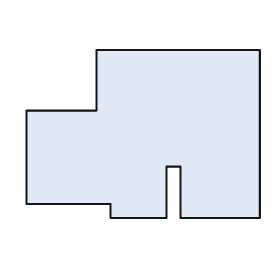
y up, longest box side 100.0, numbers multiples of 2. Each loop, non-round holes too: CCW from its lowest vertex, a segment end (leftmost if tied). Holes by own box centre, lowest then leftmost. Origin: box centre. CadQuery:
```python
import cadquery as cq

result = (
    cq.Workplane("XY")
    .moveTo(-14.0, -36.0)
    .lineTo(10.0, -36.0)
    .lineTo(10.0, -14.0)
    .lineTo(16.0, -14.0)
    .lineTo(16.0, -36.0)
    .lineTo(50.0, -36.0)
    .lineTo(50.0, 36.0)
    .lineTo(-20.0, 36.0)
    .lineTo(-20.0, 10.0)
    .lineTo(-50.0, 10.0)
    .lineTo(-50.0, -30.0)
    .lineTo(-14.0, -30.0)
    .close()
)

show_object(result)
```